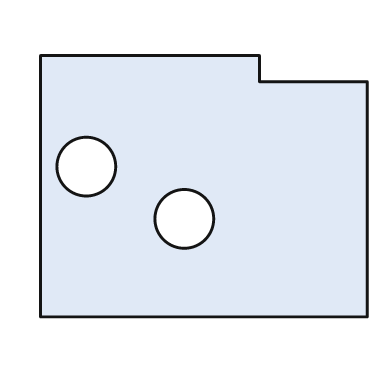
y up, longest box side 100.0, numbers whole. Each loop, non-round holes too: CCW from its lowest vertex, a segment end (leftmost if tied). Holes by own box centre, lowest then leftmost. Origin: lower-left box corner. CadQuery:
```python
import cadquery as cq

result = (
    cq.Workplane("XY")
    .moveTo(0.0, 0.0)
    .lineTo(100.0, 0.0)
    .lineTo(100.0, 72.0)
    .lineTo(67.0, 72.0)
    .lineTo(67.0, 80.0)
    .lineTo(0.0, 80.0)
    .close()
    .moveTo(44.0, 30.0)
    .circle(9.0)
    .moveTo(14.0, 46.0)
    .circle(9.0)
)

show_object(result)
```